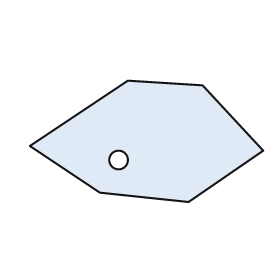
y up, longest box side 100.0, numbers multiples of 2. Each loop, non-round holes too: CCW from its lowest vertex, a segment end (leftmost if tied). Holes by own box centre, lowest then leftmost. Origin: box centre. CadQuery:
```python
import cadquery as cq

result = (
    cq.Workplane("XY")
    .moveTo(18.0, -26.0)
    .lineTo(50.0, -4.0)
    .lineTo(24.0, 24.0)
    .lineTo(-8.0, 26.0)
    .lineTo(-50.0, -2.0)
    .lineTo(-20.0, -22.0)
    .close()
    .moveTo(-12.0, -8.0)
    .circle(4.0)
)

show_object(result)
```